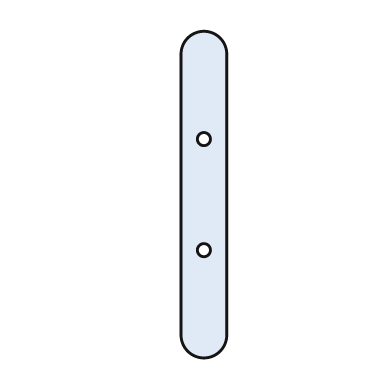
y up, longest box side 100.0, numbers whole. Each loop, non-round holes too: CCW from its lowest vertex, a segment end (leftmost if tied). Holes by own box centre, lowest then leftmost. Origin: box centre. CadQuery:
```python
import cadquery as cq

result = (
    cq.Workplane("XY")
    .moveTo(-7.0, -43.0)
    .threePointArc((0.0, -50.0), (7.0, -43.0))
    .lineTo(7.0, 43.0)
    .threePointArc((0.0, 50.0), (-7.0, 43.0))
    .close()
    .moveTo(0.0, -17.0)
    .circle(2.0)
    .moveTo(0.0, 17.0)
    .circle(2.0)
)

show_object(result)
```